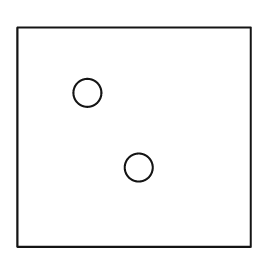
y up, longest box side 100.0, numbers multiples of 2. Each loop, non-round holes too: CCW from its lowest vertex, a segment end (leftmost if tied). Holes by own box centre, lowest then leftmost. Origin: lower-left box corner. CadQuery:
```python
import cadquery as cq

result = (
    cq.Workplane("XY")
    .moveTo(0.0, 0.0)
    .lineTo(100.0, 0.0)
    .lineTo(100.0, 94.0)
    .lineTo(0.0, 94.0)
    .close()
    .moveTo(52.0, 34.0)
    .circle(6.0)
    .moveTo(30.0, 66.0)
    .circle(6.0)
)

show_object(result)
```